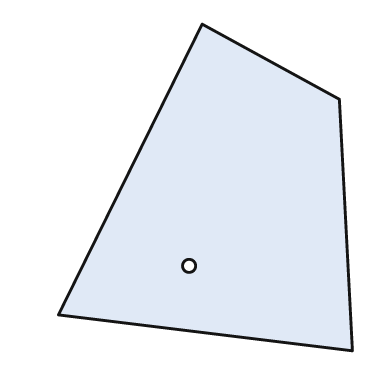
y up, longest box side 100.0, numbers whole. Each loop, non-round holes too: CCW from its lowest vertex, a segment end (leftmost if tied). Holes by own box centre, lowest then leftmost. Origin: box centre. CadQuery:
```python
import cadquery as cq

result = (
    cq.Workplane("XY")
    .moveTo(45.0, -50.0)
    .lineTo(41.0, 27.0)
    .lineTo(-1.0, 50.0)
    .lineTo(-45.0, -39.0)
    .close()
    .moveTo(-5.0, -24.0)
    .circle(2.0)
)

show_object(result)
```